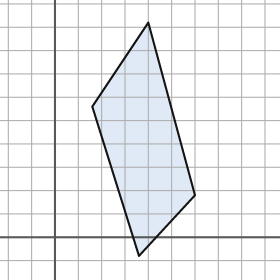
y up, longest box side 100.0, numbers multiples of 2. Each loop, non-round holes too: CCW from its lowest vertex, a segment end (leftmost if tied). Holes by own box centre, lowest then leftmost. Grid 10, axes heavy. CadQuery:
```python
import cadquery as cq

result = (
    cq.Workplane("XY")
    .moveTo(36.0, -8.0)
    .lineTo(60.0, 18.0)
    .lineTo(40.0, 92.0)
    .lineTo(16.0, 56.0)
    .close()
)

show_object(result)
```